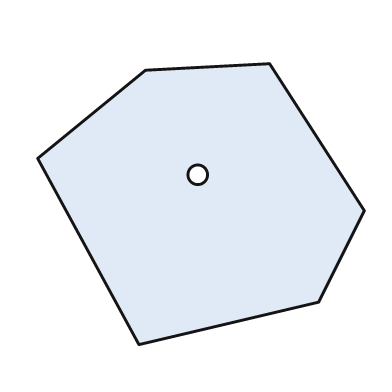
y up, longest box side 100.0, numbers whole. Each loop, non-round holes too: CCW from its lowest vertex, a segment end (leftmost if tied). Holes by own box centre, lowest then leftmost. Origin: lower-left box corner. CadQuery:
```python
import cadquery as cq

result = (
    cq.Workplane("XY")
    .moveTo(31.0, 0.0)
    .lineTo(86.0, 13.0)
    .lineTo(100.0, 41.0)
    .lineTo(71.0, 86.0)
    .lineTo(33.0, 84.0)
    .lineTo(0.0, 57.0)
    .close()
    .moveTo(49.0, 52.0)
    .circle(3.0)
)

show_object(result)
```